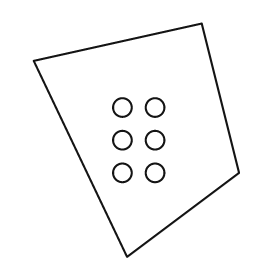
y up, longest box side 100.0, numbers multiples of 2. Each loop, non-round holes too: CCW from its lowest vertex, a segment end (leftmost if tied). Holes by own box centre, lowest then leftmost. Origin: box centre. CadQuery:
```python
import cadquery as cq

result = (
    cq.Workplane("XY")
    .moveTo(-4.0, -50.0)
    .lineTo(44.0, -14.0)
    .lineTo(28.0, 50.0)
    .lineTo(-44.0, 34.0)
    .close()
    .moveTo(-6.0, -14.0)
    .circle(4.0)
    .moveTo(8.0, -14.0)
    .circle(4.0)
    .moveTo(-6.0, 0.0)
    .circle(4.0)
    .moveTo(8.0, 0.0)
    .circle(4.0)
    .moveTo(-6.0, 14.0)
    .circle(4.0)
    .moveTo(8.0, 14.0)
    .circle(4.0)
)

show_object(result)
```